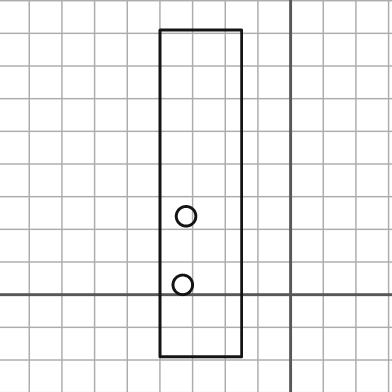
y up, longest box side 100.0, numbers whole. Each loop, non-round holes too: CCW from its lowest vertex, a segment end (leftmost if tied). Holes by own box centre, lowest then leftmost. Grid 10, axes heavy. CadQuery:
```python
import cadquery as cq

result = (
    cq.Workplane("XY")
    .moveTo(-40.0, -19.0)
    .lineTo(-15.0, -19.0)
    .lineTo(-15.0, 81.0)
    .lineTo(-40.0, 81.0)
    .close()
    .moveTo(-33.0, 3.0)
    .circle(3.0)
    .moveTo(-32.0, 24.0)
    .circle(3.0)
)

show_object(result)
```